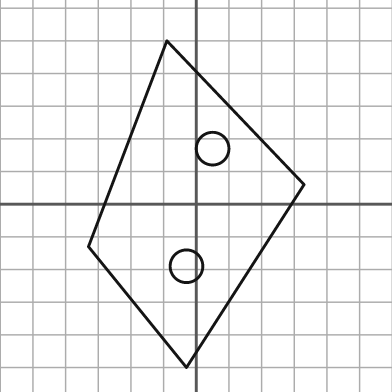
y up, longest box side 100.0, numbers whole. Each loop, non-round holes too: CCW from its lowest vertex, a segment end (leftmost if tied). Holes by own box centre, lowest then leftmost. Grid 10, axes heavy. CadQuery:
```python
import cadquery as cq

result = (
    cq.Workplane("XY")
    .moveTo(-3.0, -50.0)
    .lineTo(33.0, 6.0)
    .lineTo(-9.0, 50.0)
    .lineTo(-33.0, -13.0)
    .close()
    .moveTo(-3.0, -19.0)
    .circle(5.0)
    .moveTo(5.0, 17.0)
    .circle(5.0)
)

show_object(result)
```